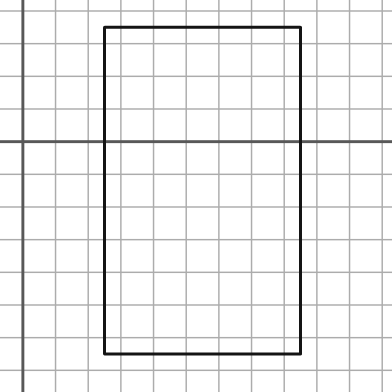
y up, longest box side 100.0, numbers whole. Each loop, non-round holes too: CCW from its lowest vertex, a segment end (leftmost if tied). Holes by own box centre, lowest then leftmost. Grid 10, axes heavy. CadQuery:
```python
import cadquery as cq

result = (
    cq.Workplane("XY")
    .moveTo(25.0, -65.0)
    .lineTo(85.0, -65.0)
    .lineTo(85.0, 35.0)
    .lineTo(25.0, 35.0)
    .close()
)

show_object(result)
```